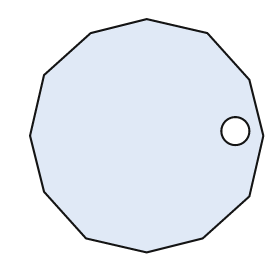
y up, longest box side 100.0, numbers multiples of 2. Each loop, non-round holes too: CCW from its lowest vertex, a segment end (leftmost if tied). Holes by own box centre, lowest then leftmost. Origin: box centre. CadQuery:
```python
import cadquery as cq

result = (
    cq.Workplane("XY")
    .moveTo(0.0, -50.0)
    .lineTo(24.0, -44.0)
    .lineTo(44.0, -26.0)
    .lineTo(50.0, 0.0)
    .lineTo(44.0, 24.0)
    .lineTo(26.0, 44.0)
    .lineTo(0.0, 50.0)
    .lineTo(-24.0, 44.0)
    .lineTo(-44.0, 26.0)
    .lineTo(-50.0, 0.0)
    .lineTo(-44.0, -24.0)
    .lineTo(-26.0, -44.0)
    .close()
    .moveTo(38.0, 2.0)
    .circle(6.0)
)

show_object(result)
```